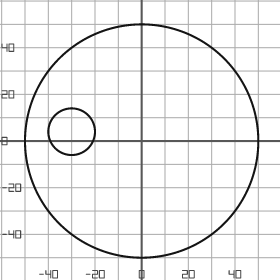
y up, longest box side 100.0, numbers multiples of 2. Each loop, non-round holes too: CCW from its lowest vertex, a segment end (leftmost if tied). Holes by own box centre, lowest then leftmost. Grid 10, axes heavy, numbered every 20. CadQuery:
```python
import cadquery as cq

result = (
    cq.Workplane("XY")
    .moveTo(0.0, 0.0)
    .circle(50.0)
    .moveTo(-30.0, 4.0)
    .circle(10.0)
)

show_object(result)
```